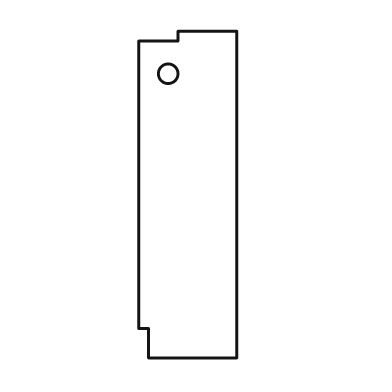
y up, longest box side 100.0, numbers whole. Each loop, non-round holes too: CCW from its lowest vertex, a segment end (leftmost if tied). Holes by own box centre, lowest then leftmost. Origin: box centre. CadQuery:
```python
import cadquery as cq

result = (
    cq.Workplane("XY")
    .moveTo(-12.0, -50.0)
    .lineTo(15.0, -50.0)
    .lineTo(15.0, 50.0)
    .lineTo(-3.0, 50.0)
    .lineTo(-3.0, 47.0)
    .lineTo(-15.0, 47.0)
    .lineTo(-15.0, -41.0)
    .lineTo(-12.0, -41.0)
    .close()
    .moveTo(-6.0, 37.0)
    .circle(3.0)
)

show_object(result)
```